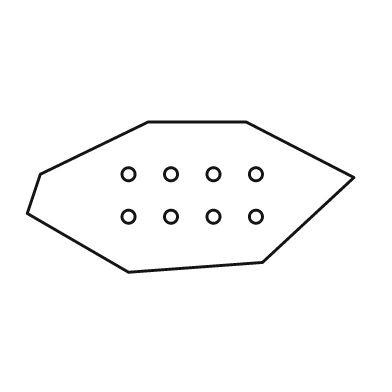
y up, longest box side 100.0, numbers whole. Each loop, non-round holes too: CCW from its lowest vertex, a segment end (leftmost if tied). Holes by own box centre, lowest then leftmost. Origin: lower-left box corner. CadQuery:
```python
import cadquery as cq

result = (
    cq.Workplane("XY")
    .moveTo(31.0, 0.0)
    .lineTo(72.0, 3.0)
    .lineTo(100.0, 29.0)
    .lineTo(67.0, 46.0)
    .lineTo(37.0, 46.0)
    .lineTo(4.0, 30.0)
    .lineTo(0.0, 18.0)
    .close()
    .moveTo(31.0, 17.0)
    .circle(2.0)
    .moveTo(44.0, 17.0)
    .circle(2.0)
    .moveTo(57.0, 17.0)
    .circle(2.0)
    .moveTo(70.0, 17.0)
    .circle(2.0)
    .moveTo(31.0, 30.0)
    .circle(2.0)
    .moveTo(44.0, 30.0)
    .circle(2.0)
    .moveTo(57.0, 30.0)
    .circle(2.0)
    .moveTo(70.0, 30.0)
    .circle(2.0)
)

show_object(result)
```